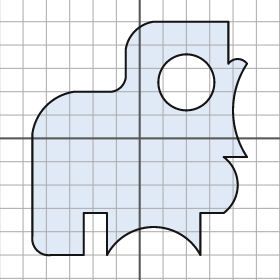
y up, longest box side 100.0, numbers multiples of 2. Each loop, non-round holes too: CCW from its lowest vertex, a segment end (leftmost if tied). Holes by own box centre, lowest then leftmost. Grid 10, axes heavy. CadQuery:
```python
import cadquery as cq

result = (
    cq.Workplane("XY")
    .moveTo(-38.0, -50.0)
    .lineTo(-24.0, -50.0)
    .lineTo(-24.0, -32.0)
    .lineTo(-14.0, -32.0)
    .lineTo(-14.0, -50.0)
    .threePointArc((6.0, -38.0), (26.0, -50.0))
    .lineTo(26.0, -32.0)
    .lineTo(36.0, -32.0)
    .threePointArc((42.0, -20.0), (36.0, -8.0))
    .lineTo(46.0, -8.0)
    .threePointArc((40.0, 12.0), (46.0, 32.0))
    .threePointArc((42.0, 34.0), (38.0, 32.0))
    .lineTo(38.0, 50.0)
    .lineTo(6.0, 50.0)
    .threePointArc((-2.0, 46.0), (-6.0, 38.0))
    .lineTo(-6.0, 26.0)
    .threePointArc((-8.0, 22.0), (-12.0, 20.0))
    .lineTo(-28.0, 20.0)
    .threePointArc((-40.0, 14.0), (-46.0, 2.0))
    .lineTo(-46.0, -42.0)
    .threePointArc((-44.0, -48.0), (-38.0, -50.0))
    .close()
    .moveTo(20.0, 24.0)
    .circle(12.0)
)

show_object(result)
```